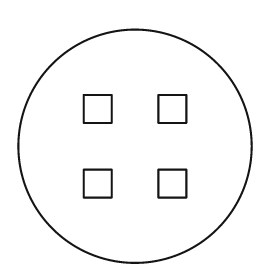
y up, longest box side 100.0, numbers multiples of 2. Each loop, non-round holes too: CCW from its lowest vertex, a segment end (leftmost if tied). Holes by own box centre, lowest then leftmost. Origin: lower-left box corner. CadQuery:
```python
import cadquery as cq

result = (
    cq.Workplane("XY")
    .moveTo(50.0, 50.0)
    .circle(50.0)
    .moveTo(28.0, 28.0)
    .lineTo(40.0, 28.0)
    .lineTo(40.0, 40.0)
    .lineTo(28.0, 40.0)
    .close()
    .moveTo(60.0, 28.0)
    .lineTo(72.0, 28.0)
    .lineTo(72.0, 40.0)
    .lineTo(60.0, 40.0)
    .close()
    .moveTo(28.0, 60.0)
    .lineTo(40.0, 60.0)
    .lineTo(40.0, 72.0)
    .lineTo(28.0, 72.0)
    .close()
    .moveTo(60.0, 60.0)
    .lineTo(72.0, 60.0)
    .lineTo(72.0, 72.0)
    .lineTo(60.0, 72.0)
    .close()
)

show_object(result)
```